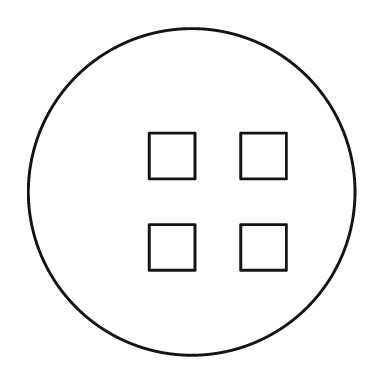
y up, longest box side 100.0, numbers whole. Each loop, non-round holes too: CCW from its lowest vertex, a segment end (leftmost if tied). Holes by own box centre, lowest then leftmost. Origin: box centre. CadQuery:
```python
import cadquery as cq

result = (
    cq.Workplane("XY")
    .moveTo(0.0, 0.0)
    .circle(50.0)
    .moveTo(-13.0, -24.0)
    .lineTo(1.0, -24.0)
    .lineTo(1.0, -10.0)
    .lineTo(-13.0, -10.0)
    .close()
    .moveTo(15.0, -24.0)
    .lineTo(29.0, -24.0)
    .lineTo(29.0, -10.0)
    .lineTo(15.0, -10.0)
    .close()
    .moveTo(-13.0, 4.0)
    .lineTo(1.0, 4.0)
    .lineTo(1.0, 18.0)
    .lineTo(-13.0, 18.0)
    .close()
    .moveTo(15.0, 4.0)
    .lineTo(29.0, 4.0)
    .lineTo(29.0, 18.0)
    .lineTo(15.0, 18.0)
    .close()
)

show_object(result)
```